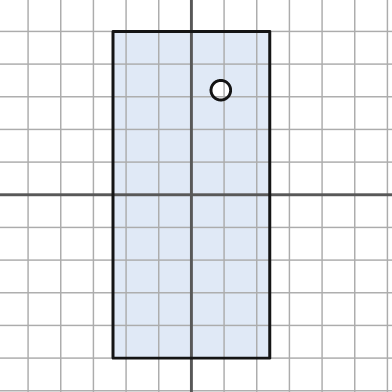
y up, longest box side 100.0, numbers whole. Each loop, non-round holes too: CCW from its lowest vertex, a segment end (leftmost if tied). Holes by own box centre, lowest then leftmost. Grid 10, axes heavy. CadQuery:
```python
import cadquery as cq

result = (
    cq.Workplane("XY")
    .moveTo(-24.0, -50.0)
    .lineTo(24.0, -50.0)
    .lineTo(24.0, 50.0)
    .lineTo(-24.0, 50.0)
    .close()
    .moveTo(9.0, 32.0)
    .circle(3.0)
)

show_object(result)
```